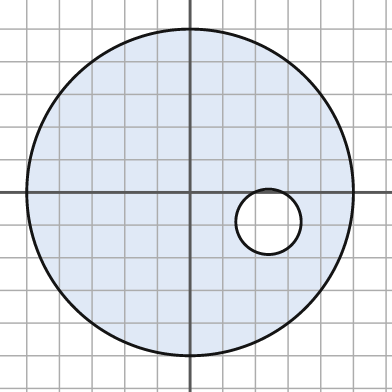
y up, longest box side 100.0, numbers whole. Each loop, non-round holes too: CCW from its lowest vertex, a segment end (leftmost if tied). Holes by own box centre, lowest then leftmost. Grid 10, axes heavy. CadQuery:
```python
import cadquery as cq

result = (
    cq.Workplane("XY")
    .moveTo(0.0, 0.0)
    .circle(50.0)
    .moveTo(24.0, -9.0)
    .circle(10.0)
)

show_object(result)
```